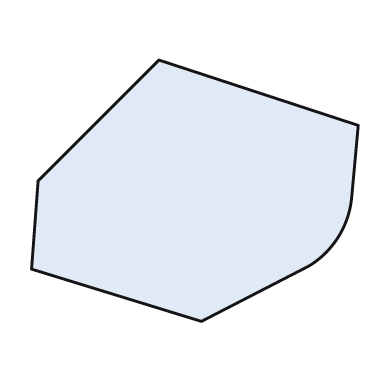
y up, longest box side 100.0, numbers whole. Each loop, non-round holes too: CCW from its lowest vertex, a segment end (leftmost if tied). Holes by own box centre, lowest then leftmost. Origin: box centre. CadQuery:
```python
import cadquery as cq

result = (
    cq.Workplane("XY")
    .moveTo(2.0, -40.0)
    .lineTo(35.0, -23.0)
    .threePointArc((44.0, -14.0), (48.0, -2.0))
    .lineTo(50.0, 20.0)
    .lineTo(-11.0, 40.0)
    .lineTo(-48.0, 3.0)
    .lineTo(-50.0, -24.0)
    .close()
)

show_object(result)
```